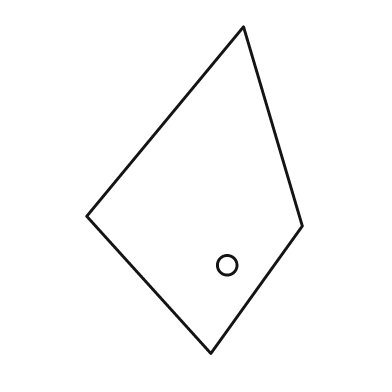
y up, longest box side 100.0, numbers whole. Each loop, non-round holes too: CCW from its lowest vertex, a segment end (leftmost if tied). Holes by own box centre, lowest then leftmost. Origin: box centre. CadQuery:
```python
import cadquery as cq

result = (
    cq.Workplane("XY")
    .moveTo(5.0, -50.0)
    .lineTo(33.0, -11.0)
    .lineTo(15.0, 50.0)
    .lineTo(-33.0, -8.0)
    .close()
    .moveTo(10.0, -23.0)
    .circle(3.0)
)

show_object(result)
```